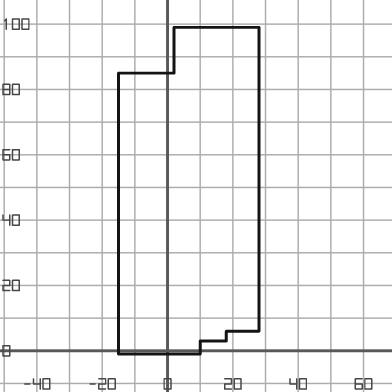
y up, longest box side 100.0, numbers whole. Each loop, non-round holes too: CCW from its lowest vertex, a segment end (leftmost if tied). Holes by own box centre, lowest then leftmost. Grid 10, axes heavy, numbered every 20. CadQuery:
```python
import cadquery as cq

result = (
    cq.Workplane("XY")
    .moveTo(-15.0, -1.0)
    .lineTo(10.0, -1.0)
    .lineTo(10.0, 3.0)
    .lineTo(18.0, 3.0)
    .lineTo(18.0, 6.0)
    .lineTo(28.0, 6.0)
    .lineTo(28.0, 99.0)
    .lineTo(2.0, 99.0)
    .lineTo(2.0, 85.0)
    .lineTo(-15.0, 85.0)
    .close()
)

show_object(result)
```